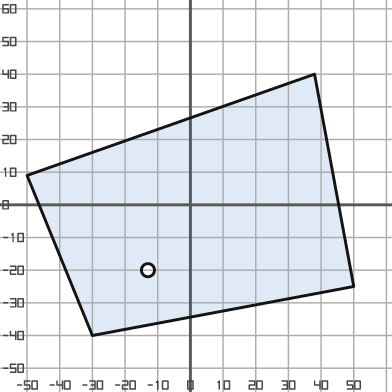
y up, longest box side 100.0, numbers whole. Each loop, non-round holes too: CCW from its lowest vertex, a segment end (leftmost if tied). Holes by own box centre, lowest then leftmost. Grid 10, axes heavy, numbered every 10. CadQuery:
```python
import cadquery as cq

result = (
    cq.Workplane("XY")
    .moveTo(-30.0, -40.0)
    .lineTo(50.0, -25.0)
    .lineTo(38.0, 40.0)
    .lineTo(-50.0, 9.0)
    .close()
    .moveTo(-13.0, -20.0)
    .circle(2.0)
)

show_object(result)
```